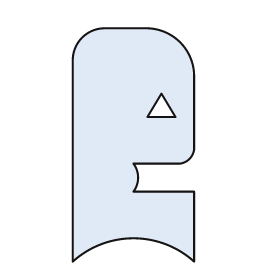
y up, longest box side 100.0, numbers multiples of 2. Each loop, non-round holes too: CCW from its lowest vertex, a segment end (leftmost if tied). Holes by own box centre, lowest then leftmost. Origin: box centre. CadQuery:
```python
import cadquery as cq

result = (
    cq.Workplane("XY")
    .moveTo(-26.0, -50.0)
    .threePointArc((0.0, -40.0), (26.0, -50.0))
    .lineTo(26.0, -20.0)
    .lineTo(0.0, -20.0)
    .threePointArc((2.0, -14.0), (0.0, -8.0))
    .lineTo(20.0, -8.0)
    .threePointArc((24.0, -6.0), (26.0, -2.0))
    .lineTo(26.0, 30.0)
    .threePointArc((20.0, 44.0), (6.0, 50.0))
    .lineTo(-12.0, 50.0)
    .threePointArc((-22.0, 46.0), (-26.0, 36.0))
    .close()
    .moveTo(6.0, 12.0)
    .lineTo(18.0, 12.0)
    .lineTo(12.0, 22.0)
    .close()
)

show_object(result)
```